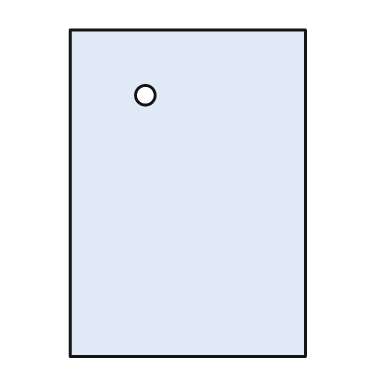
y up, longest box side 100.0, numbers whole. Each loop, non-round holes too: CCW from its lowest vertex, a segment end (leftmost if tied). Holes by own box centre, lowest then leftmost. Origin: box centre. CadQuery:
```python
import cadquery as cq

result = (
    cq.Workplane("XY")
    .moveTo(-36.0, -50.0)
    .lineTo(36.0, -50.0)
    .lineTo(36.0, 50.0)
    .lineTo(-36.0, 50.0)
    .close()
    .moveTo(-13.0, 30.0)
    .circle(3.0)
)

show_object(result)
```